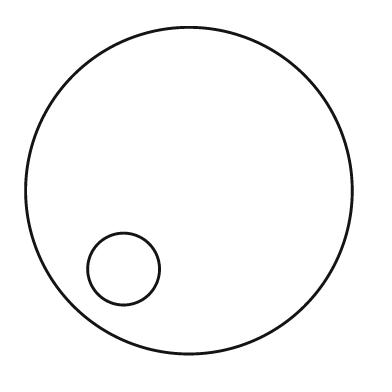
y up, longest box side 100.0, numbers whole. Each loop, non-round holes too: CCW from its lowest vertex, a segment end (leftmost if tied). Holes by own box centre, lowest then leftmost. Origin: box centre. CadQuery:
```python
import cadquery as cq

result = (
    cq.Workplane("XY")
    .moveTo(0.0, 0.0)
    .circle(50.0)
    .moveTo(-20.0, -24.0)
    .circle(11.0)
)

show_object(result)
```